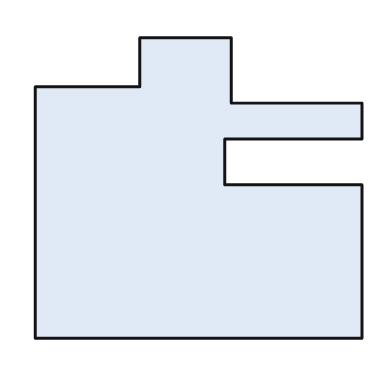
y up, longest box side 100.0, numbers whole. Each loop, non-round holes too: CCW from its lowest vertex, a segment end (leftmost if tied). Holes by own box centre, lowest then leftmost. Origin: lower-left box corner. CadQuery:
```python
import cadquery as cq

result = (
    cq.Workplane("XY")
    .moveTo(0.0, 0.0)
    .lineTo(100.0, 0.0)
    .lineTo(100.0, 47.0)
    .lineTo(58.0, 47.0)
    .lineTo(58.0, 61.0)
    .lineTo(100.0, 61.0)
    .lineTo(100.0, 72.0)
    .lineTo(60.0, 72.0)
    .lineTo(60.0, 92.0)
    .lineTo(32.0, 92.0)
    .lineTo(32.0, 77.0)
    .lineTo(0.0, 77.0)
    .close()
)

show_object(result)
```